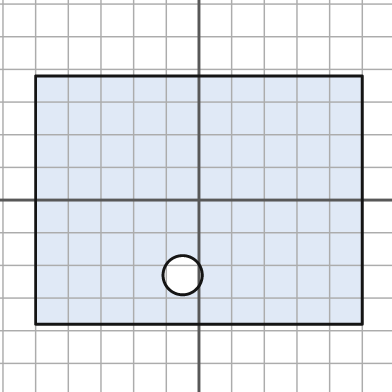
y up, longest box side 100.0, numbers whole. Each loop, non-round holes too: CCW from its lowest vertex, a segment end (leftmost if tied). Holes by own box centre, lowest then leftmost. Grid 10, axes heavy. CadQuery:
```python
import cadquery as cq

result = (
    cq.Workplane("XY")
    .moveTo(-50.0, -38.0)
    .lineTo(50.0, -38.0)
    .lineTo(50.0, 38.0)
    .lineTo(-50.0, 38.0)
    .close()
    .moveTo(-5.0, -23.0)
    .circle(6.0)
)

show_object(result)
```